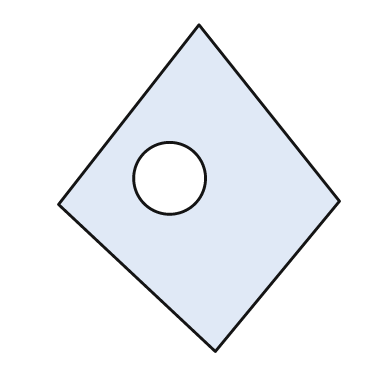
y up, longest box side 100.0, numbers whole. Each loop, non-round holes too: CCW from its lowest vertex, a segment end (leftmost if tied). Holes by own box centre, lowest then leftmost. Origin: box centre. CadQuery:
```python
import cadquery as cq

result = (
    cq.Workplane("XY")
    .moveTo(5.0, -50.0)
    .lineTo(43.0, -4.0)
    .lineTo(0.0, 50.0)
    .lineTo(-43.0, -5.0)
    .close()
    .moveTo(-9.0, 3.0)
    .circle(11.0)
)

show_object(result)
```